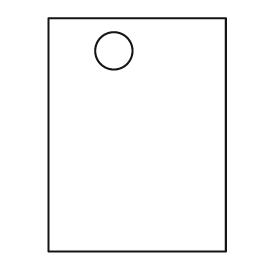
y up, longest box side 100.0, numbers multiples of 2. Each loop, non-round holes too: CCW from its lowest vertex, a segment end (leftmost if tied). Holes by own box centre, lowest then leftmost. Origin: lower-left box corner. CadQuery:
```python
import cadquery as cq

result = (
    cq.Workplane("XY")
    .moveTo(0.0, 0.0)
    .lineTo(76.0, 0.0)
    .lineTo(76.0, 100.0)
    .lineTo(0.0, 100.0)
    .close()
    .moveTo(28.0, 86.0)
    .circle(8.0)
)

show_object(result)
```